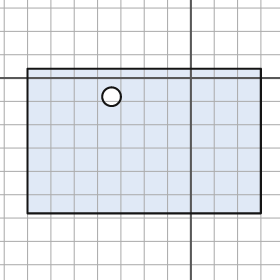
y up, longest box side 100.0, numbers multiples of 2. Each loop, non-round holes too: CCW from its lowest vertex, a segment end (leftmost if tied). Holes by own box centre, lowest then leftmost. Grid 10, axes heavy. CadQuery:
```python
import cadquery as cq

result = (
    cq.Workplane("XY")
    .moveTo(-70.0, -58.0)
    .lineTo(30.0, -58.0)
    .lineTo(30.0, 4.0)
    .lineTo(-70.0, 4.0)
    .close()
    .moveTo(-34.0, -8.0)
    .circle(4.0)
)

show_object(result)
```